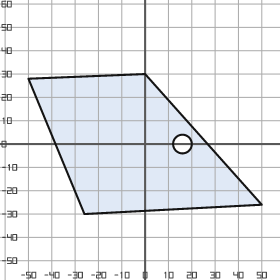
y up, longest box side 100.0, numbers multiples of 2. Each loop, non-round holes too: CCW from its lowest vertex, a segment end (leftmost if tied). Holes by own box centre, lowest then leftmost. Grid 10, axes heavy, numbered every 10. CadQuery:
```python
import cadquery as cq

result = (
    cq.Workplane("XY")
    .moveTo(-26.0, -30.0)
    .lineTo(50.0, -26.0)
    .lineTo(0.0, 30.0)
    .lineTo(-50.0, 28.0)
    .close()
    .moveTo(16.0, 0.0)
    .circle(4.0)
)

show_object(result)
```